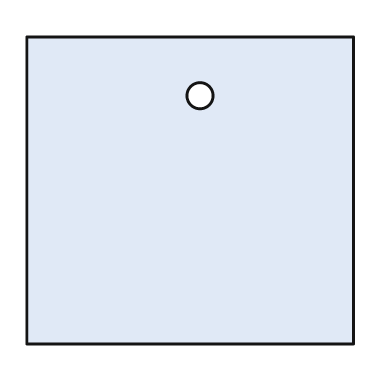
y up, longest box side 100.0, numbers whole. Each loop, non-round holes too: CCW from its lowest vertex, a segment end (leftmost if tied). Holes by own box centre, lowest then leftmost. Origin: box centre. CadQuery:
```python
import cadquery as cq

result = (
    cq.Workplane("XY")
    .moveTo(-50.0, -47.0)
    .lineTo(50.0, -47.0)
    .lineTo(50.0, 47.0)
    .lineTo(-50.0, 47.0)
    .close()
    .moveTo(3.0, 29.0)
    .circle(4.0)
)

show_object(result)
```